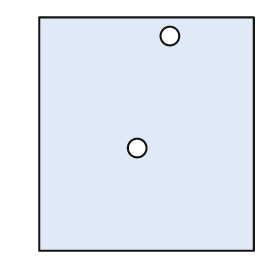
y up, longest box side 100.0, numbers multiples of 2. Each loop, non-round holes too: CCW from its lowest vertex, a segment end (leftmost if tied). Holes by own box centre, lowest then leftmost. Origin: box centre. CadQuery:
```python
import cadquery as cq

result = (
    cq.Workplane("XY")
    .moveTo(-46.0, -50.0)
    .lineTo(46.0, -50.0)
    .lineTo(46.0, 50.0)
    .lineTo(-46.0, 50.0)
    .close()
    .moveTo(-4.0, -6.0)
    .circle(4.0)
    .moveTo(10.0, 42.0)
    .circle(4.0)
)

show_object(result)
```